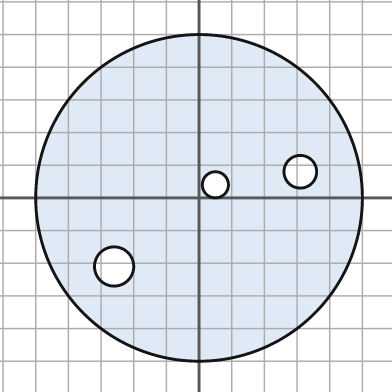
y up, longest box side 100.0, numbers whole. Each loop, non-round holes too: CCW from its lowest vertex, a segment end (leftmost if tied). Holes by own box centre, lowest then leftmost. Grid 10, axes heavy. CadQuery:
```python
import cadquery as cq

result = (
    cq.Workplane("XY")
    .moveTo(0.0, 0.0)
    .circle(50.0)
    .moveTo(-26.0, -21.0)
    .circle(6.0)
    .moveTo(5.0, 4.0)
    .circle(4.0)
    .moveTo(31.0, 8.0)
    .circle(5.0)
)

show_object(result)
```